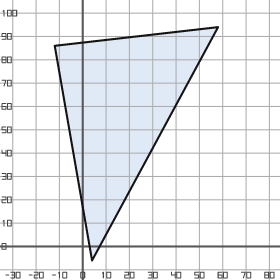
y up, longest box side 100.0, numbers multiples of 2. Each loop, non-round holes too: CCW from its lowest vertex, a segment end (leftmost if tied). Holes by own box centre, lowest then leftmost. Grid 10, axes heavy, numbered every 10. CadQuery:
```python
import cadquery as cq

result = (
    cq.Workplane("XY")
    .moveTo(4.0, -6.0)
    .lineTo(58.0, 94.0)
    .lineTo(-12.0, 86.0)
    .close()
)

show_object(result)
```